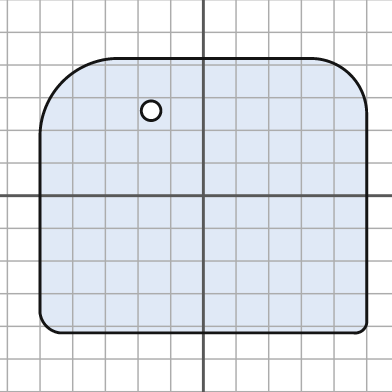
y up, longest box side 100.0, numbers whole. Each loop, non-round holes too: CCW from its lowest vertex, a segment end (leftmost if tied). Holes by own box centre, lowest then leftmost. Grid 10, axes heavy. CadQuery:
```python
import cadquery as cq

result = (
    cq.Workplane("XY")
    .moveTo(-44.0, -42.0)
    .lineTo(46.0, -42.0)
    .threePointArc((49.0, -41.0), (50.0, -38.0))
    .lineTo(50.0, 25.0)
    .threePointArc((45.0, 37.0), (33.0, 42.0))
    .lineTo(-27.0, 42.0)
    .threePointArc((-43.0, 35.0), (-50.0, 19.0))
    .lineTo(-50.0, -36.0)
    .threePointArc((-48.0, -40.0), (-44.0, -42.0))
    .close()
    .moveTo(-16.0, 26.0)
    .circle(3.0)
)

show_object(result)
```